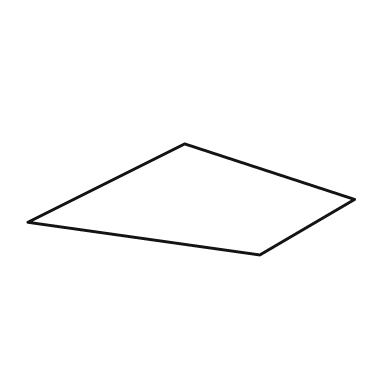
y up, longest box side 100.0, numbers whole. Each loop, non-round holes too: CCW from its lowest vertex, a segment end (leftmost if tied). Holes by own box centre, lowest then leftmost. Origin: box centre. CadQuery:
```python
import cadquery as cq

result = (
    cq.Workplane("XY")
    .moveTo(21.0, -17.0)
    .lineTo(50.0, 0.0)
    .lineTo(-2.0, 17.0)
    .lineTo(-50.0, -7.0)
    .close()
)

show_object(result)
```